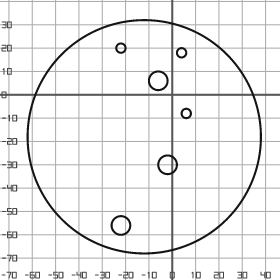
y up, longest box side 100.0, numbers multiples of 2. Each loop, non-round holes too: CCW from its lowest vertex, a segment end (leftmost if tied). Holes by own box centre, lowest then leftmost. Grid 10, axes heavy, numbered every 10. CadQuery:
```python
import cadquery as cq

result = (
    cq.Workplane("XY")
    .moveTo(-12.0, -18.0)
    .circle(50.0)
    .moveTo(-22.0, -56.0)
    .circle(4.0)
    .moveTo(-2.0, -30.0)
    .circle(4.0)
    .moveTo(6.0, -8.0)
    .circle(2.0)
    .moveTo(-6.0, 6.0)
    .circle(4.0)
    .moveTo(4.0, 18.0)
    .circle(2.0)
    .moveTo(-22.0, 20.0)
    .circle(2.0)
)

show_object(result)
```